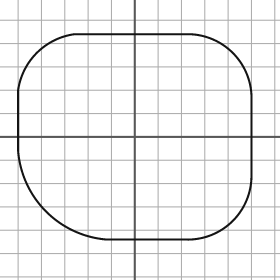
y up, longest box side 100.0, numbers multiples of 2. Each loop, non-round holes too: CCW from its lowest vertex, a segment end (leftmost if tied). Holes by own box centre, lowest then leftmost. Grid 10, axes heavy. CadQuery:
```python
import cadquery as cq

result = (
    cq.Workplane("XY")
    .moveTo(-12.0, -44.0)
    .lineTo(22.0, -44.0)
    .threePointArc((42.0, -36.0), (50.0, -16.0))
    .lineTo(50.0, 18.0)
    .threePointArc((42.0, 36.0), (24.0, 44.0))
    .lineTo(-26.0, 44.0)
    .threePointArc((-42.0, 36.0), (-50.0, 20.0))
    .lineTo(-50.0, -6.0)
    .threePointArc((-38.0, -32.0), (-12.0, -44.0))
    .close()
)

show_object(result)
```